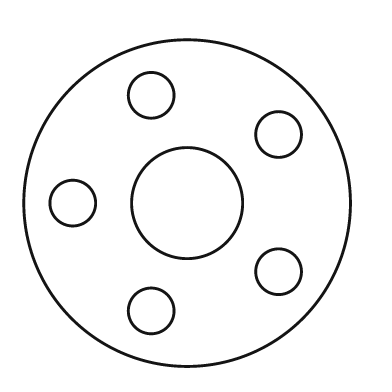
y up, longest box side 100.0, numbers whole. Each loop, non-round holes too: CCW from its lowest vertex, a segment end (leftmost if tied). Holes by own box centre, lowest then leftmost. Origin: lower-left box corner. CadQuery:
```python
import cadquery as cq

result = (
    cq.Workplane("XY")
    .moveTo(50.0, 50.0)
    .circle(50.0)
    .moveTo(39.0, 17.0)
    .circle(7.0)
    .moveTo(78.0, 29.0)
    .circle(7.0)
    .moveTo(15.0, 50.0)
    .circle(7.0)
    .moveTo(50.0, 50.0)
    .circle(17.0)
    .moveTo(78.0, 71.0)
    .circle(7.0)
    .moveTo(39.0, 83.0)
    .circle(7.0)
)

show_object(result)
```